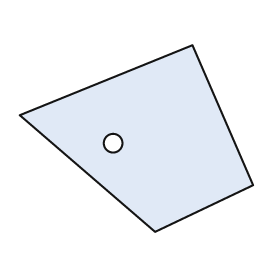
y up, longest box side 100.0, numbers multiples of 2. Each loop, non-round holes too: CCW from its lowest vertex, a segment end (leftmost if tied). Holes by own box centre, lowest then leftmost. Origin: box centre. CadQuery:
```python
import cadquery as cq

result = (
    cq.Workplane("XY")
    .moveTo(8.0, -40.0)
    .lineTo(50.0, -20.0)
    .lineTo(24.0, 40.0)
    .lineTo(-50.0, 10.0)
    .close()
    .moveTo(-10.0, -2.0)
    .circle(4.0)
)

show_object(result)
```